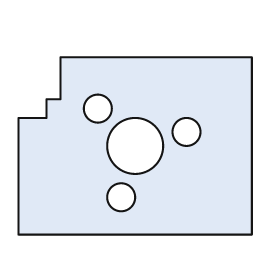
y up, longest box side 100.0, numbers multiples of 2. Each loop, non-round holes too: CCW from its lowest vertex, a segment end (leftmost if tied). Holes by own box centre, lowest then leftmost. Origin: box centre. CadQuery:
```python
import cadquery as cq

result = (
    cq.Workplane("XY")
    .moveTo(-50.0, -38.0)
    .lineTo(50.0, -38.0)
    .lineTo(50.0, 38.0)
    .lineTo(-32.0, 38.0)
    .lineTo(-32.0, 20.0)
    .lineTo(-38.0, 20.0)
    .lineTo(-38.0, 12.0)
    .lineTo(-50.0, 12.0)
    .close()
    .moveTo(-6.0, -22.0)
    .circle(6.0)
    .moveTo(0.0, 0.0)
    .circle(12.0)
    .moveTo(22.0, 6.0)
    .circle(6.0)
    .moveTo(-16.0, 16.0)
    .circle(6.0)
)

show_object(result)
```